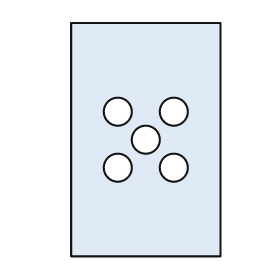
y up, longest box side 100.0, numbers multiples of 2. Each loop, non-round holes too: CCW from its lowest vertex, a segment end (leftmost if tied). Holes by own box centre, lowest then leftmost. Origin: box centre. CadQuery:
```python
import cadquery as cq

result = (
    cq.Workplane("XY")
    .moveTo(-32.0, -50.0)
    .lineTo(32.0, -50.0)
    .lineTo(32.0, 50.0)
    .lineTo(-32.0, 50.0)
    .close()
    .moveTo(-12.0, -12.0)
    .circle(6.0)
    .moveTo(12.0, -12.0)
    .circle(6.0)
    .moveTo(0.0, 0.0)
    .circle(6.0)
    .moveTo(-12.0, 12.0)
    .circle(6.0)
    .moveTo(12.0, 12.0)
    .circle(6.0)
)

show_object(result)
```